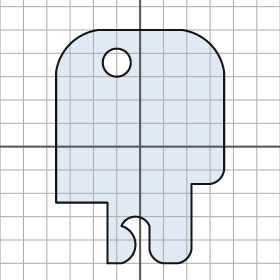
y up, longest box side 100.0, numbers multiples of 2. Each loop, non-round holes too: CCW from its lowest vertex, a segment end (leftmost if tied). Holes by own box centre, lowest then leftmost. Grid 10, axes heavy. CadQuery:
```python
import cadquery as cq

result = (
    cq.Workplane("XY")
    .moveTo(-14.0, -50.0)
    .lineTo(-8.0, -50.0)
    .threePointArc((-2.0, -42.0), (-8.0, -34.0))
    .threePointArc((-2.0, -30.0), (4.0, -34.0))
    .lineTo(4.0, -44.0)
    .threePointArc((6.0, -48.0), (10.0, -50.0))
    .lineTo(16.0, -50.0)
    .threePointArc((20.0, -48.0), (22.0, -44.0))
    .lineTo(22.0, -16.0)
    .lineTo(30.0, -16.0)
    .threePointArc((34.0, -14.0), (36.0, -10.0))
    .lineTo(36.0, 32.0)
    .threePointArc((30.0, 44.0), (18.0, 50.0))
    .lineTo(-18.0, 50.0)
    .threePointArc((-30.0, 44.0), (-36.0, 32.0))
    .lineTo(-36.0, -24.0)
    .lineTo(-14.0, -24.0)
    .close()
    .moveTo(-10.0, 36.0)
    .circle(6.0)
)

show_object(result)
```